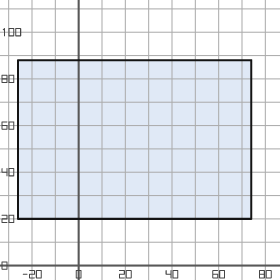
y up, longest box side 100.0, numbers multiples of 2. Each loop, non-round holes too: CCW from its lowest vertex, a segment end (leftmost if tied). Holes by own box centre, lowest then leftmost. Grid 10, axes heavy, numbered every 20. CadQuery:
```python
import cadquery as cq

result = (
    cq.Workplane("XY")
    .moveTo(-26.0, 20.0)
    .lineTo(74.0, 20.0)
    .lineTo(74.0, 88.0)
    .lineTo(-26.0, 88.0)
    .close()
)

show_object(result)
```